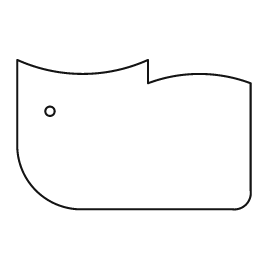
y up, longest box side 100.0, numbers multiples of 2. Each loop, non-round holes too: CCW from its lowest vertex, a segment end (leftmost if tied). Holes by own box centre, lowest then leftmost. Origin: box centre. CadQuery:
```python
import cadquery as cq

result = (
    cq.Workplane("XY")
    .moveTo(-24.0, -32.0)
    .lineTo(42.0, -32.0)
    .threePointArc((48.0, -30.0), (50.0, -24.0))
    .lineTo(50.0, 22.0)
    .threePointArc((28.0, 26.0), (6.0, 22.0))
    .lineTo(6.0, 32.0)
    .threePointArc((-22.0, 26.0), (-50.0, 32.0))
    .lineTo(-50.0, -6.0)
    .threePointArc((-42.0, -24.0), (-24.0, -32.0))
    .close()
    .moveTo(-36.0, 10.0)
    .circle(2.0)
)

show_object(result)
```